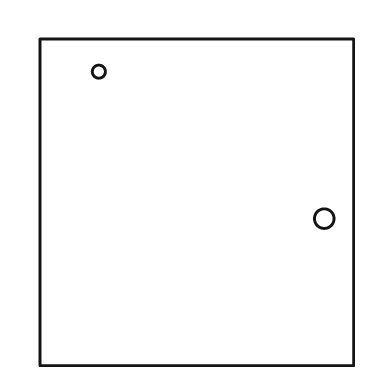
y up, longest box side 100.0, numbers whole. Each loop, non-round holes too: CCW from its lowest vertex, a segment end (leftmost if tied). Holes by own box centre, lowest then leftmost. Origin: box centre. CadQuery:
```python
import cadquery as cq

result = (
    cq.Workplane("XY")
    .moveTo(-48.0, -50.0)
    .lineTo(48.0, -50.0)
    .lineTo(48.0, 50.0)
    .lineTo(-48.0, 50.0)
    .close()
    .moveTo(39.0, -5.0)
    .circle(3.0)
    .moveTo(-30.0, 40.0)
    .circle(2.0)
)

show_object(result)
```